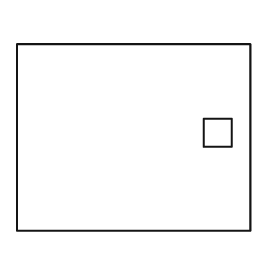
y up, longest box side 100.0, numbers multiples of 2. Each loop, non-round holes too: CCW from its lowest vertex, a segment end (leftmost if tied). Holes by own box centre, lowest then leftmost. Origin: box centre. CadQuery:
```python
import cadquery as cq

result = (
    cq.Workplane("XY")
    .moveTo(-50.0, -40.0)
    .lineTo(50.0, -40.0)
    .lineTo(50.0, 40.0)
    .lineTo(-50.0, 40.0)
    .close()
    .moveTo(30.0, -4.0)
    .lineTo(42.0, -4.0)
    .lineTo(42.0, 8.0)
    .lineTo(30.0, 8.0)
    .close()
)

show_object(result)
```